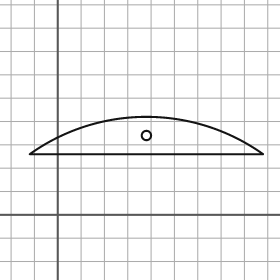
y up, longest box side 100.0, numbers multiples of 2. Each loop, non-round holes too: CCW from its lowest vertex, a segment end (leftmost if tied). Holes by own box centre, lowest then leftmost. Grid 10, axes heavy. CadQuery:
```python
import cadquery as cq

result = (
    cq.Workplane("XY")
    .moveTo(-12.0, 26.0)
    .lineTo(88.0, 26.0)
    .threePointArc((38.0, 42.0), (-12.0, 26.0))
    .close()
    .moveTo(38.0, 34.0)
    .circle(2.0)
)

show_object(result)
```